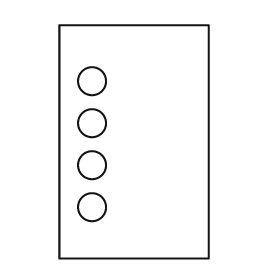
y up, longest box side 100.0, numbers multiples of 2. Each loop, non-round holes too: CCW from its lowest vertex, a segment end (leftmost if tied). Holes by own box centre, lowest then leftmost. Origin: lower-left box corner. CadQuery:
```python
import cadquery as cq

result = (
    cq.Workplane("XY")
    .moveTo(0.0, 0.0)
    .lineTo(64.0, 0.0)
    .lineTo(64.0, 100.0)
    .lineTo(0.0, 100.0)
    .close()
    .moveTo(14.0, 22.0)
    .circle(6.0)
    .moveTo(14.0, 40.0)
    .circle(6.0)
    .moveTo(14.0, 58.0)
    .circle(6.0)
    .moveTo(14.0, 76.0)
    .circle(6.0)
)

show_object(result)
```